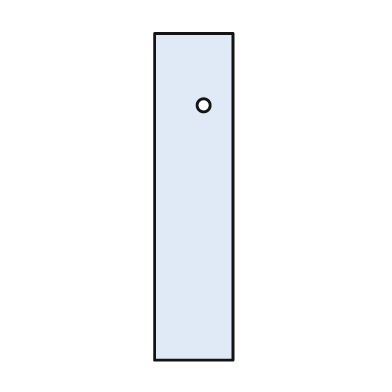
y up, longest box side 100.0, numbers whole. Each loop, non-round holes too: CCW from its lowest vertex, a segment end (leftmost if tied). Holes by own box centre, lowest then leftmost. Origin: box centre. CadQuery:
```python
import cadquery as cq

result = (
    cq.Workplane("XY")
    .moveTo(-12.0, -50.0)
    .lineTo(12.0, -50.0)
    .lineTo(12.0, 50.0)
    .lineTo(-12.0, 50.0)
    .close()
    .moveTo(3.0, 28.0)
    .circle(2.0)
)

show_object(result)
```